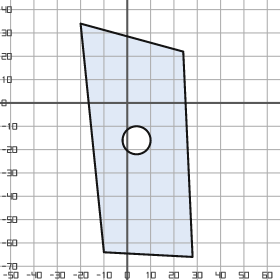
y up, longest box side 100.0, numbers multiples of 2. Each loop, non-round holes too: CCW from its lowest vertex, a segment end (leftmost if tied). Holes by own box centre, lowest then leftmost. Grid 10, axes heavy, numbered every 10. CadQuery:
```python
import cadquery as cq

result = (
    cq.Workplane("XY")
    .moveTo(28.0, -66.0)
    .lineTo(24.0, 22.0)
    .lineTo(-20.0, 34.0)
    .lineTo(-10.0, -64.0)
    .close()
    .moveTo(4.0, -16.0)
    .circle(6.0)
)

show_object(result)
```